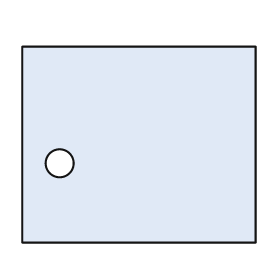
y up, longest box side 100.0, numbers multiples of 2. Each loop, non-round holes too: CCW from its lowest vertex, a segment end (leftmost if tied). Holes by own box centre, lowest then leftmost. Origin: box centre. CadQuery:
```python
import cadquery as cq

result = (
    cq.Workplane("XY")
    .moveTo(-50.0, -42.0)
    .lineTo(50.0, -42.0)
    .lineTo(50.0, 42.0)
    .lineTo(-50.0, 42.0)
    .close()
    .moveTo(-34.0, -8.0)
    .circle(6.0)
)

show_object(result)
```